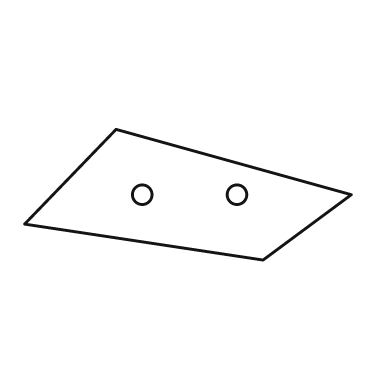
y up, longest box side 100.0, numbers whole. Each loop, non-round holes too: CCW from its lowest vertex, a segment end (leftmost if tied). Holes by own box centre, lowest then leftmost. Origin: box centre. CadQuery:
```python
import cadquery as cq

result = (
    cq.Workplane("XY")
    .moveTo(23.0, -20.0)
    .lineTo(50.0, 0.0)
    .lineTo(-22.0, 20.0)
    .lineTo(-50.0, -9.0)
    .close()
    .moveTo(-14.0, 0.0)
    .circle(3.0)
    .moveTo(15.0, 0.0)
    .circle(3.0)
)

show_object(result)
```